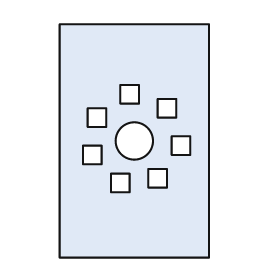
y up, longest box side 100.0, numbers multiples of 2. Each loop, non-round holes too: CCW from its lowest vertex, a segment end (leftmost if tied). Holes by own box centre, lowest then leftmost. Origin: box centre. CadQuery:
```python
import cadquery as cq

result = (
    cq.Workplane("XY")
    .moveTo(-32.0, -50.0)
    .lineTo(32.0, -50.0)
    .lineTo(32.0, 50.0)
    .lineTo(-32.0, 50.0)
    .close()
    .moveTo(-10.0, -22.0)
    .lineTo(-2.0, -22.0)
    .lineTo(-2.0, -14.0)
    .lineTo(-10.0, -14.0)
    .close()
    .moveTo(6.0, -20.0)
    .lineTo(14.0, -20.0)
    .lineTo(14.0, -12.0)
    .lineTo(6.0, -12.0)
    .close()
    .moveTo(-22.0, -10.0)
    .lineTo(-14.0, -10.0)
    .lineTo(-14.0, -2.0)
    .lineTo(-22.0, -2.0)
    .close()
    .moveTo(16.0, -6.0)
    .lineTo(24.0, -6.0)
    .lineTo(24.0, 2.0)
    .lineTo(16.0, 2.0)
    .close()
    .moveTo(0.0, 0.0)
    .circle(8.0)
    .moveTo(-20.0, 6.0)
    .lineTo(-12.0, 6.0)
    .lineTo(-12.0, 14.0)
    .lineTo(-20.0, 14.0)
    .close()
    .moveTo(10.0, 10.0)
    .lineTo(18.0, 10.0)
    .lineTo(18.0, 18.0)
    .lineTo(10.0, 18.0)
    .close()
    .moveTo(-6.0, 16.0)
    .lineTo(2.0, 16.0)
    .lineTo(2.0, 24.0)
    .lineTo(-6.0, 24.0)
    .close()
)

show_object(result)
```